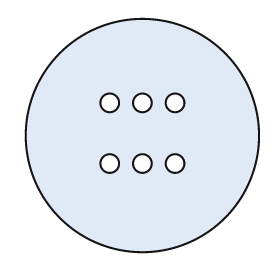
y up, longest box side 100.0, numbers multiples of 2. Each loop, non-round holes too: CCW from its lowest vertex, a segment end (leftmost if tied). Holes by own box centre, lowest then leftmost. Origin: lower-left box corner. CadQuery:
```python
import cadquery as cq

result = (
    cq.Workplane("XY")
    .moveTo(50.0, 50.0)
    .circle(50.0)
    .moveTo(36.0, 38.0)
    .circle(4.0)
    .moveTo(50.0, 38.0)
    .circle(4.0)
    .moveTo(64.0, 38.0)
    .circle(4.0)
    .moveTo(36.0, 64.0)
    .circle(4.0)
    .moveTo(50.0, 64.0)
    .circle(4.0)
    .moveTo(64.0, 64.0)
    .circle(4.0)
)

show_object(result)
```